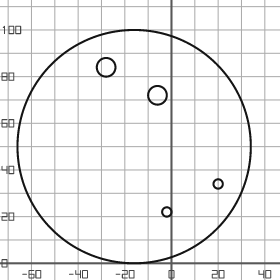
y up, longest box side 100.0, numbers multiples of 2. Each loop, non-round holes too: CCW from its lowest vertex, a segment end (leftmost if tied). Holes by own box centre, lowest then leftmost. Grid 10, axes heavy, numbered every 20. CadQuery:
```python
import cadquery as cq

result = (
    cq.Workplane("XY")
    .moveTo(-16.0, 50.0)
    .circle(50.0)
    .moveTo(-2.0, 22.0)
    .circle(2.0)
    .moveTo(20.0, 34.0)
    .circle(2.0)
    .moveTo(-6.0, 72.0)
    .circle(4.0)
    .moveTo(-28.0, 84.0)
    .circle(4.0)
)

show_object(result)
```